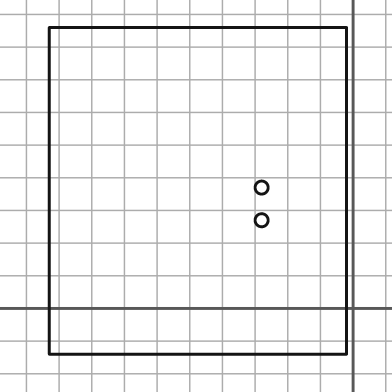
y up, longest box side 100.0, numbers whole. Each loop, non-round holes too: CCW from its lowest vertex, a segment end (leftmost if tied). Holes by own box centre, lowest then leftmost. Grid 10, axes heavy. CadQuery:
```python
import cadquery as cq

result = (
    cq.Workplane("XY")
    .moveTo(-93.0, -14.0)
    .lineTo(-2.0, -14.0)
    .lineTo(-2.0, 86.0)
    .lineTo(-93.0, 86.0)
    .close()
    .moveTo(-28.0, 27.0)
    .circle(2.0)
    .moveTo(-28.0, 37.0)
    .circle(2.0)
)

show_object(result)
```